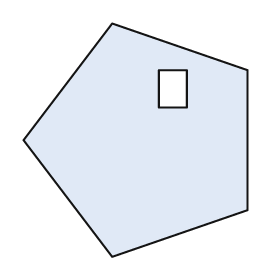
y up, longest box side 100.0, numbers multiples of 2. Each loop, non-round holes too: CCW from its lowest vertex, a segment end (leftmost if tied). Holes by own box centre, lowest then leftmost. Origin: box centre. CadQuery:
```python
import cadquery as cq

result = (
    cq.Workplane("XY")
    .moveTo(-10.0, -50.0)
    .lineTo(48.0, -30.0)
    .lineTo(48.0, 30.0)
    .lineTo(-10.0, 50.0)
    .lineTo(-48.0, 0.0)
    .close()
    .moveTo(10.0, 14.0)
    .lineTo(22.0, 14.0)
    .lineTo(22.0, 30.0)
    .lineTo(10.0, 30.0)
    .close()
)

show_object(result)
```